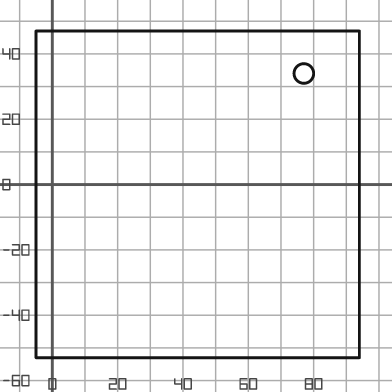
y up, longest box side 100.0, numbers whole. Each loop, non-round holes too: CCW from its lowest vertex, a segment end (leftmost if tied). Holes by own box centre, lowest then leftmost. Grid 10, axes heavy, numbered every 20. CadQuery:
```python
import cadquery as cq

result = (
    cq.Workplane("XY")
    .moveTo(-5.0, -53.0)
    .lineTo(94.0, -53.0)
    .lineTo(94.0, 47.0)
    .lineTo(-5.0, 47.0)
    .close()
    .moveTo(77.0, 34.0)
    .circle(3.0)
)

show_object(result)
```